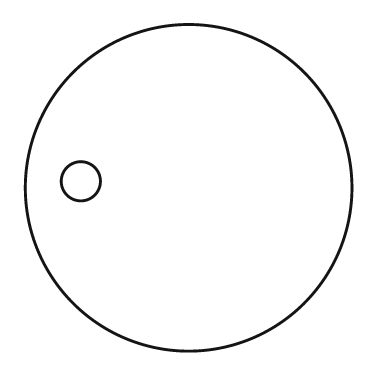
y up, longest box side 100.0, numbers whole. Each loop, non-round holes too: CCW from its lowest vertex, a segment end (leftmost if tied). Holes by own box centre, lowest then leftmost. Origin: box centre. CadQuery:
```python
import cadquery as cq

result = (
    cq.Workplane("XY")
    .moveTo(0.0, 0.0)
    .circle(50.0)
    .moveTo(-33.0, 2.0)
    .circle(6.0)
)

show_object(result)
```